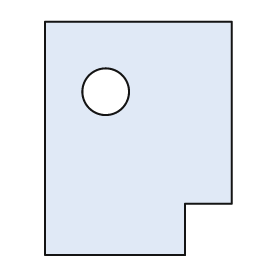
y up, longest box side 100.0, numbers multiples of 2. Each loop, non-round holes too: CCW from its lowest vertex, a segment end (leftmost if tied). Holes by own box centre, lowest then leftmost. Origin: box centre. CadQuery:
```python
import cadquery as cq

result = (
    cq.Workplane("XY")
    .moveTo(-40.0, -50.0)
    .lineTo(20.0, -50.0)
    .lineTo(20.0, -28.0)
    .lineTo(40.0, -28.0)
    .lineTo(40.0, 50.0)
    .lineTo(-40.0, 50.0)
    .close()
    .moveTo(-14.0, 20.0)
    .circle(10.0)
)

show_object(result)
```